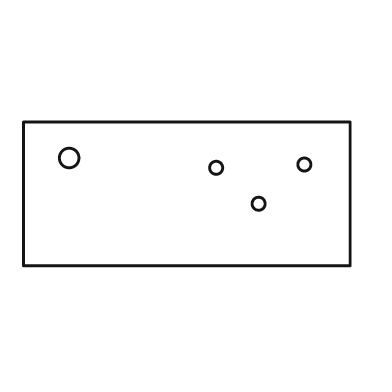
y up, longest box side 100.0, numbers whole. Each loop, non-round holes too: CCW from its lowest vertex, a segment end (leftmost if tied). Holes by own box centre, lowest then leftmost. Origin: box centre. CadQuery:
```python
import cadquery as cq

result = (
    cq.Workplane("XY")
    .moveTo(-50.0, -22.0)
    .lineTo(50.0, -22.0)
    .lineTo(50.0, 22.0)
    .lineTo(-50.0, 22.0)
    .close()
    .moveTo(22.0, -3.0)
    .circle(2.0)
    .moveTo(9.0, 8.0)
    .circle(2.0)
    .moveTo(36.0, 9.0)
    .circle(2.0)
    .moveTo(-36.0, 11.0)
    .circle(3.0)
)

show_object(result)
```